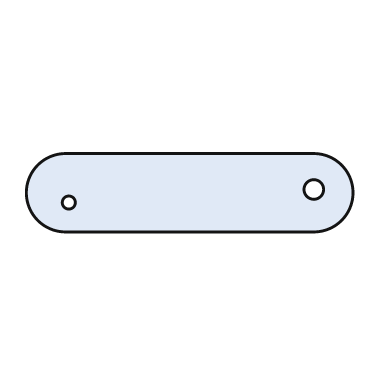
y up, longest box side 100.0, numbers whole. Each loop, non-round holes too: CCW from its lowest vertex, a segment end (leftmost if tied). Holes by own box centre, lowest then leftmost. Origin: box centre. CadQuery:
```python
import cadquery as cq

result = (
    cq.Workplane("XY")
    .moveTo(-38.0, -12.0)
    .lineTo(38.0, -12.0)
    .threePointArc((50.0, 0.0), (38.0, 12.0))
    .lineTo(-38.0, 12.0)
    .threePointArc((-50.0, 0.0), (-38.0, -12.0))
    .close()
    .moveTo(-37.0, -3.0)
    .circle(2.0)
    .moveTo(38.0, 1.0)
    .circle(3.0)
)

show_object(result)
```